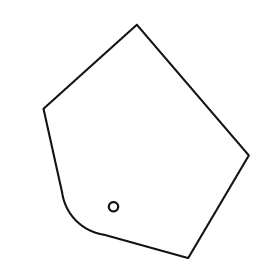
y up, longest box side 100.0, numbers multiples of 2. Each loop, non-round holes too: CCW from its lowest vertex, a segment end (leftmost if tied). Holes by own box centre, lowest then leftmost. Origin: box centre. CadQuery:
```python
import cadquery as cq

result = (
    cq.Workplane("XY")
    .moveTo(18.0, -50.0)
    .lineTo(44.0, -6.0)
    .lineTo(-4.0, 50.0)
    .lineTo(-44.0, 14.0)
    .lineTo(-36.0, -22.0)
    .threePointArc((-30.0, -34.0), (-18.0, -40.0))
    .close()
    .moveTo(-14.0, -28.0)
    .circle(2.0)
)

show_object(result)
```